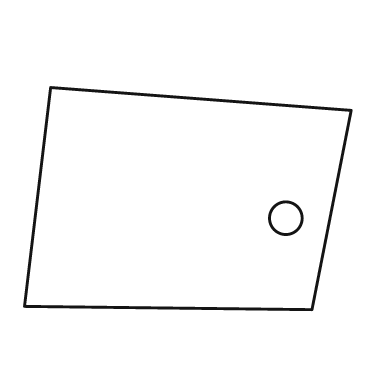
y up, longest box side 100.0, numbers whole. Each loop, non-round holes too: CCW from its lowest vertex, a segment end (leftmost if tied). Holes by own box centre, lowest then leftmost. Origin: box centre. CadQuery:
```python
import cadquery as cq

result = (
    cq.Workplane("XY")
    .moveTo(38.0, -34.0)
    .lineTo(50.0, 27.0)
    .lineTo(-42.0, 34.0)
    .lineTo(-50.0, -33.0)
    .close()
    .moveTo(30.0, -6.0)
    .circle(5.0)
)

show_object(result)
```